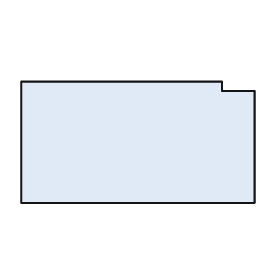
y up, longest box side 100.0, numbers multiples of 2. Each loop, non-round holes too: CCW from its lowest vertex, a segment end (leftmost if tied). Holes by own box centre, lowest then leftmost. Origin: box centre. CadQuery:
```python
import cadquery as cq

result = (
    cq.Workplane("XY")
    .moveTo(-50.0, -26.0)
    .lineTo(50.0, -26.0)
    .lineTo(50.0, 22.0)
    .lineTo(36.0, 22.0)
    .lineTo(36.0, 26.0)
    .lineTo(-50.0, 26.0)
    .close()
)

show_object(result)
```